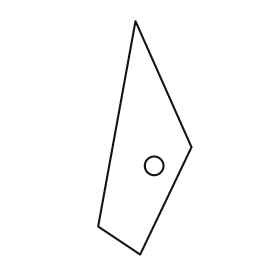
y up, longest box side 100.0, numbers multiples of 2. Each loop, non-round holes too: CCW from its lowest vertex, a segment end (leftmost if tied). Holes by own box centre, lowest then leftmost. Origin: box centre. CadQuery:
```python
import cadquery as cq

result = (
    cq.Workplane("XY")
    .moveTo(-2.0, -50.0)
    .lineTo(20.0, -4.0)
    .lineTo(-4.0, 50.0)
    .lineTo(-20.0, -38.0)
    .close()
    .moveTo(4.0, -12.0)
    .circle(4.0)
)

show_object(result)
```